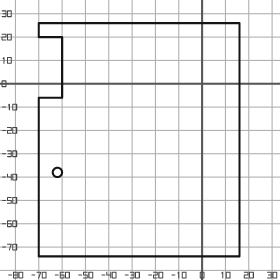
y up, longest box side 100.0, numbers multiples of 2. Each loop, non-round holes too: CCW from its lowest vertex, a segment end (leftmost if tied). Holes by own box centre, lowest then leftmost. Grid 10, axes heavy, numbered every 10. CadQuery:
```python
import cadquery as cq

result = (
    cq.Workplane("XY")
    .moveTo(-70.0, -74.0)
    .lineTo(16.0, -74.0)
    .lineTo(16.0, 26.0)
    .lineTo(-70.0, 26.0)
    .lineTo(-70.0, 20.0)
    .lineTo(-60.0, 20.0)
    .lineTo(-60.0, -6.0)
    .lineTo(-70.0, -6.0)
    .close()
    .moveTo(-62.0, -38.0)
    .circle(2.0)
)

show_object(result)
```